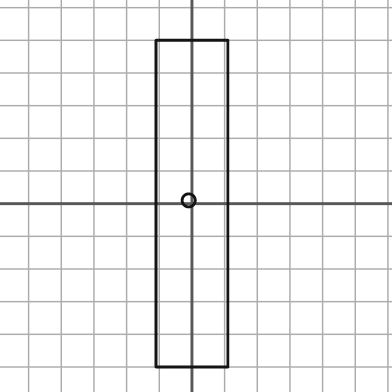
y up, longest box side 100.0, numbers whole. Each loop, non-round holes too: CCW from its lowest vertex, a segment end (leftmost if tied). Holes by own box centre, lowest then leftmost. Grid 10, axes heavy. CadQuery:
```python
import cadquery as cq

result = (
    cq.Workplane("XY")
    .moveTo(-11.0, -50.0)
    .lineTo(11.0, -50.0)
    .lineTo(11.0, 50.0)
    .lineTo(-11.0, 50.0)
    .close()
    .moveTo(-1.0, 1.0)
    .circle(2.0)
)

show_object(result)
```